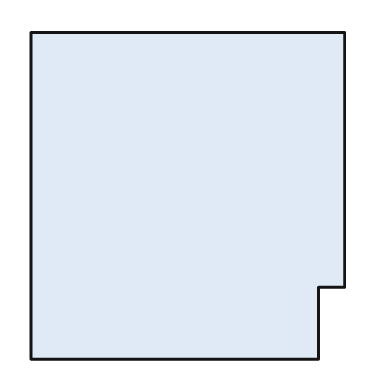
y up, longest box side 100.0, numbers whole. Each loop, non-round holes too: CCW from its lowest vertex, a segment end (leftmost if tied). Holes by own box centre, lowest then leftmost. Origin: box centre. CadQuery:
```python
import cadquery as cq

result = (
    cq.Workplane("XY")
    .moveTo(-48.0, -50.0)
    .lineTo(40.0, -50.0)
    .lineTo(40.0, -28.0)
    .lineTo(48.0, -28.0)
    .lineTo(48.0, 50.0)
    .lineTo(-48.0, 50.0)
    .close()
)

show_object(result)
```